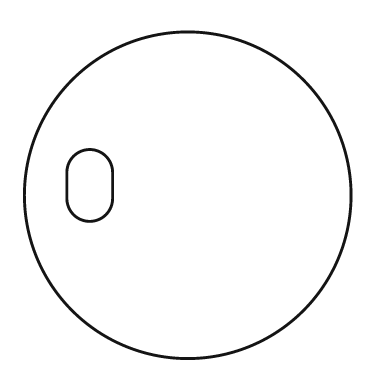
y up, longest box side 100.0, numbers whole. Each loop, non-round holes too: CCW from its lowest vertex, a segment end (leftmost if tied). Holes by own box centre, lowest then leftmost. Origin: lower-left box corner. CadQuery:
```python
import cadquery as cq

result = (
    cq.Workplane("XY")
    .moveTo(50.0, 50.0)
    .circle(50.0)
    .moveTo(13.0, 49.0)
    .threePointArc((20.0, 42.0), (27.0, 49.0))
    .lineTo(27.0, 57.0)
    .threePointArc((20.0, 64.0), (13.0, 57.0))
    .close()
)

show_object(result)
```